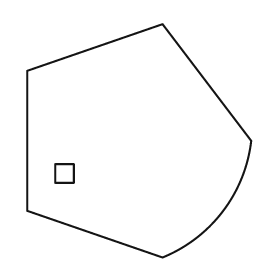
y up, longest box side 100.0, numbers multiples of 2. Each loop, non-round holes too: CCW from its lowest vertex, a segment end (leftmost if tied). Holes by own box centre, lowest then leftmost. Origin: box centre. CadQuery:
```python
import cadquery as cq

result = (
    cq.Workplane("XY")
    .moveTo(10.0, -50.0)
    .threePointArc((36.0, -30.0), (48.0, 0.0))
    .lineTo(10.0, 50.0)
    .lineTo(-48.0, 30.0)
    .lineTo(-48.0, -30.0)
    .close()
    .moveTo(-36.0, -18.0)
    .lineTo(-28.0, -18.0)
    .lineTo(-28.0, -10.0)
    .lineTo(-36.0, -10.0)
    .close()
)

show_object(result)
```